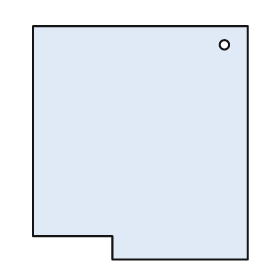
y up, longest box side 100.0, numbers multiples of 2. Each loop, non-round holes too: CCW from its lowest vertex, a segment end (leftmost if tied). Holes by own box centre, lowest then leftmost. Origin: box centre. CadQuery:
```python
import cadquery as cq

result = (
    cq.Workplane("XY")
    .moveTo(-12.0, -50.0)
    .lineTo(46.0, -50.0)
    .lineTo(46.0, 50.0)
    .lineTo(-46.0, 50.0)
    .lineTo(-46.0, -40.0)
    .lineTo(-12.0, -40.0)
    .close()
    .moveTo(36.0, 42.0)
    .circle(2.0)
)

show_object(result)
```